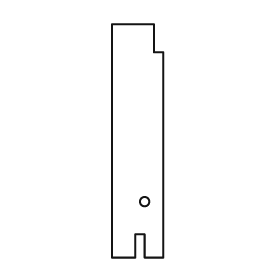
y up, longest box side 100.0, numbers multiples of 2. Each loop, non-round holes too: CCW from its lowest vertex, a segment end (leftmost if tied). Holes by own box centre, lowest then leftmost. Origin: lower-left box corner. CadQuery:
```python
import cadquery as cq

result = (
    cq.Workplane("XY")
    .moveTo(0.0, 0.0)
    .lineTo(10.0, 0.0)
    .lineTo(10.0, 10.0)
    .lineTo(14.0, 10.0)
    .lineTo(14.0, 0.0)
    .lineTo(22.0, 0.0)
    .lineTo(22.0, 88.0)
    .lineTo(18.0, 88.0)
    .lineTo(18.0, 100.0)
    .lineTo(0.0, 100.0)
    .close()
    .moveTo(14.0, 24.0)
    .circle(2.0)
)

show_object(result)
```